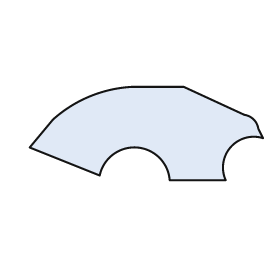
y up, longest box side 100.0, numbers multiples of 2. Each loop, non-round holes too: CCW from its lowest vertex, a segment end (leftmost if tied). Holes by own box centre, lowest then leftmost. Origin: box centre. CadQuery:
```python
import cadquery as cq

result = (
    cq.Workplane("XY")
    .moveTo(10.0, -20.0)
    .lineTo(34.0, -20.0)
    .threePointArc((36.0, -6.0), (50.0, -2.0))
    .lineTo(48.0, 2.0)
    .threePointArc((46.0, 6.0), (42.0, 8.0))
    .lineTo(16.0, 20.0)
    .lineTo(-6.0, 20.0)
    .threePointArc((-24.0, 16.0), (-40.0, 6.0))
    .lineTo(-50.0, -6.0)
    .lineTo(-20.0, -18.0)
    .threePointArc((-4.0, -6.0), (10.0, -20.0))
    .close()
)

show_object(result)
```